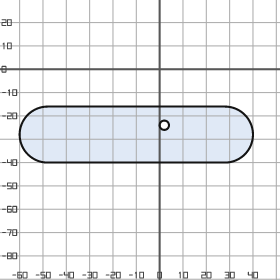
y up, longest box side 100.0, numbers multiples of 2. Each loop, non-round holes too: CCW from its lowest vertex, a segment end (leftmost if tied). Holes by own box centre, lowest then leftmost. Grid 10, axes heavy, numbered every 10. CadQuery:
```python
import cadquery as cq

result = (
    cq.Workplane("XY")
    .moveTo(-48.0, -40.0)
    .lineTo(28.0, -40.0)
    .threePointArc((40.0, -28.0), (28.0, -16.0))
    .lineTo(-48.0, -16.0)
    .threePointArc((-60.0, -28.0), (-48.0, -40.0))
    .close()
    .moveTo(2.0, -24.0)
    .circle(2.0)
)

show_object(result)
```